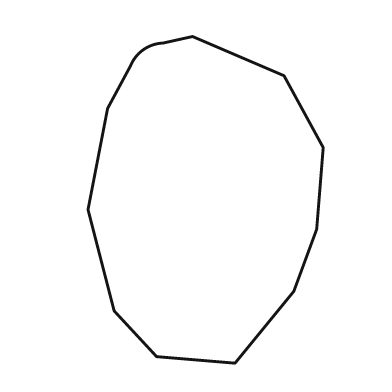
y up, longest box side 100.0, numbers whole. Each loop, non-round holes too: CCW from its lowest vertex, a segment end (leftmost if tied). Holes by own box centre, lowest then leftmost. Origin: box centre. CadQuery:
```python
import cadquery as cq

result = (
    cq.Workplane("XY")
    .moveTo(9.0, -50.0)
    .lineTo(27.0, -28.0)
    .lineTo(34.0, -9.0)
    .lineTo(36.0, 16.0)
    .lineTo(24.0, 38.0)
    .lineTo(-4.0, 50.0)
    .lineTo(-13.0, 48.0)
    .threePointArc((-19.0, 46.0), (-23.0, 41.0))
    .lineTo(-30.0, 28.0)
    .lineTo(-36.0, -3.0)
    .lineTo(-28.0, -34.0)
    .lineTo(-15.0, -48.0)
    .close()
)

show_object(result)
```